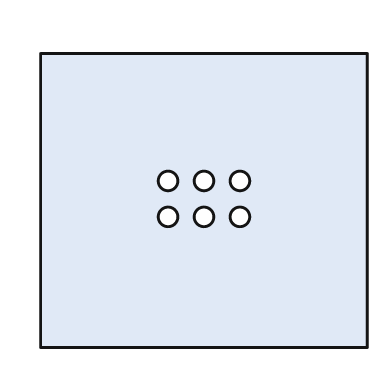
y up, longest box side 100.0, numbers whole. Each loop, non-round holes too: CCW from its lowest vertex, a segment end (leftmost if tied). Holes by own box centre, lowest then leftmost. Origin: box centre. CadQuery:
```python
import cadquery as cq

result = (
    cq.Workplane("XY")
    .moveTo(-50.0, -45.0)
    .lineTo(50.0, -45.0)
    .lineTo(50.0, 45.0)
    .lineTo(-50.0, 45.0)
    .close()
    .moveTo(-11.0, -5.0)
    .circle(3.0)
    .moveTo(0.0, -5.0)
    .circle(3.0)
    .moveTo(11.0, -5.0)
    .circle(3.0)
    .moveTo(-11.0, 6.0)
    .circle(3.0)
    .moveTo(0.0, 6.0)
    .circle(3.0)
    .moveTo(11.0, 6.0)
    .circle(3.0)
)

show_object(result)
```